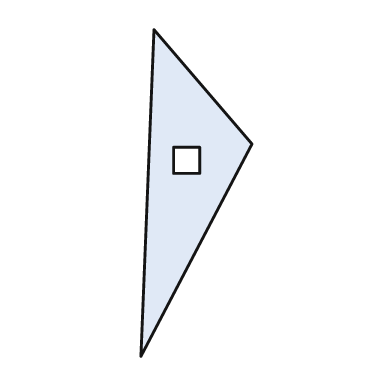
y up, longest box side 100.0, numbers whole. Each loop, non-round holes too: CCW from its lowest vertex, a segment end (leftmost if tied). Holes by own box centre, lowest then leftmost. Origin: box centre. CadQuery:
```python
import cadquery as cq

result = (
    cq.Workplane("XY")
    .moveTo(-17.0, -50.0)
    .lineTo(17.0, 15.0)
    .lineTo(-13.0, 50.0)
    .close()
    .moveTo(-7.0, 6.0)
    .lineTo(1.0, 6.0)
    .lineTo(1.0, 14.0)
    .lineTo(-7.0, 14.0)
    .close()
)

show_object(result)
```